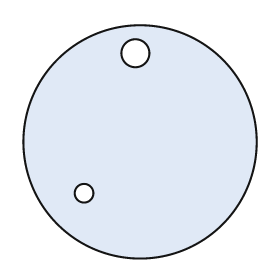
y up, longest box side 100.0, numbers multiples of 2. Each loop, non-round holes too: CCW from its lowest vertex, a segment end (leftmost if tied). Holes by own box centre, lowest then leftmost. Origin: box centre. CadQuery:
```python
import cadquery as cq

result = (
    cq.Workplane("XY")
    .moveTo(0.0, 0.0)
    .circle(50.0)
    .moveTo(-24.0, -22.0)
    .circle(4.0)
    .moveTo(-2.0, 38.0)
    .circle(6.0)
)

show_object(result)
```